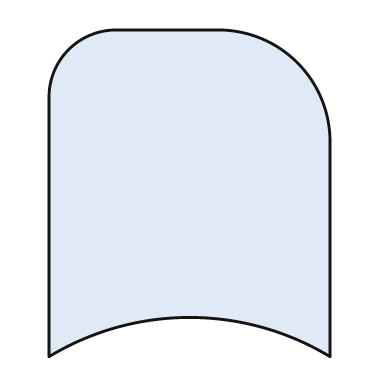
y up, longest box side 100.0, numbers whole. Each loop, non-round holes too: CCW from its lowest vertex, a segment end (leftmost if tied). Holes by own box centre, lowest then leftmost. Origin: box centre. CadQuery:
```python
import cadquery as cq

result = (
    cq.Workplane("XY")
    .moveTo(-43.0, -50.0)
    .threePointArc((0.0, -38.0), (43.0, -50.0))
    .lineTo(43.0, 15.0)
    .threePointArc((33.0, 40.0), (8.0, 50.0))
    .lineTo(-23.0, 50.0)
    .threePointArc((-37.0, 44.0), (-43.0, 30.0))
    .close()
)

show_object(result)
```